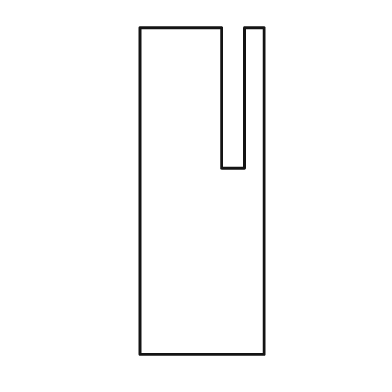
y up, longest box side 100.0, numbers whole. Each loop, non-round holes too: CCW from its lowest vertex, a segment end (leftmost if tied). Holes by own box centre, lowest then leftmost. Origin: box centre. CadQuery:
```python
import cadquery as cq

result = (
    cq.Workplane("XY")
    .moveTo(-19.0, -50.0)
    .lineTo(19.0, -50.0)
    .lineTo(19.0, 50.0)
    .lineTo(13.0, 50.0)
    .lineTo(13.0, 7.0)
    .lineTo(6.0, 7.0)
    .lineTo(6.0, 50.0)
    .lineTo(-19.0, 50.0)
    .close()
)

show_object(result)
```